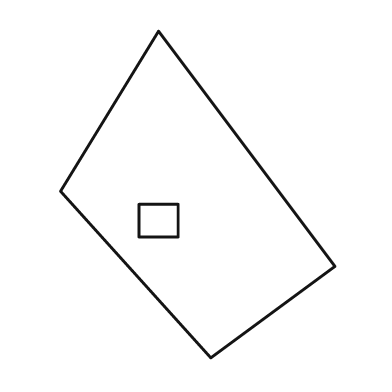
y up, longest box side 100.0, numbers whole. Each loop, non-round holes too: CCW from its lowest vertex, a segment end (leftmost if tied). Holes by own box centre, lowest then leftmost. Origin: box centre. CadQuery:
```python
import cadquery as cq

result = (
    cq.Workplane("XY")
    .moveTo(4.0, -50.0)
    .lineTo(42.0, -22.0)
    .lineTo(-12.0, 50.0)
    .lineTo(-42.0, 1.0)
    .close()
    .moveTo(-18.0, -13.0)
    .lineTo(-6.0, -13.0)
    .lineTo(-6.0, -3.0)
    .lineTo(-18.0, -3.0)
    .close()
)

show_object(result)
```